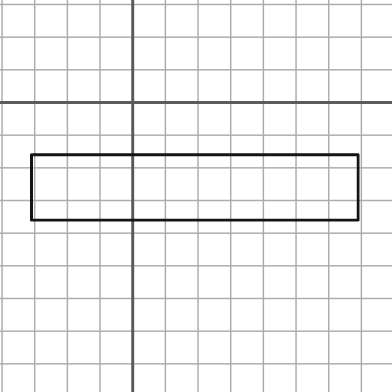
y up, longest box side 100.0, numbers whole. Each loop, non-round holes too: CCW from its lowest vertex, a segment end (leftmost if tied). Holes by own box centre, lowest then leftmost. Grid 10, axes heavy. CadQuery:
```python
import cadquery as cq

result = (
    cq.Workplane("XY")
    .moveTo(-31.0, -36.0)
    .lineTo(69.0, -36.0)
    .lineTo(69.0, -16.0)
    .lineTo(-31.0, -16.0)
    .close()
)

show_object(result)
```